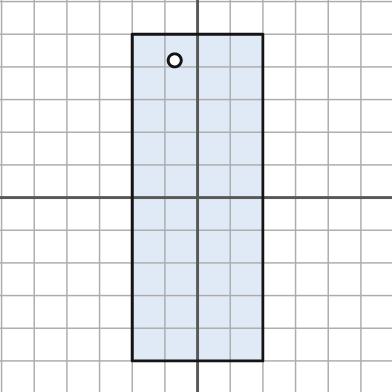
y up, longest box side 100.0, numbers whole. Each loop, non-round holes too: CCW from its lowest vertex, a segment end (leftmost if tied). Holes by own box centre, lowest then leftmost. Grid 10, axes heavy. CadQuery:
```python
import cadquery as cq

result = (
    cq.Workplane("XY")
    .moveTo(-20.0, -50.0)
    .lineTo(20.0, -50.0)
    .lineTo(20.0, 50.0)
    .lineTo(-20.0, 50.0)
    .close()
    .moveTo(-7.0, 42.0)
    .circle(2.0)
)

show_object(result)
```